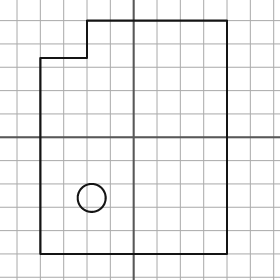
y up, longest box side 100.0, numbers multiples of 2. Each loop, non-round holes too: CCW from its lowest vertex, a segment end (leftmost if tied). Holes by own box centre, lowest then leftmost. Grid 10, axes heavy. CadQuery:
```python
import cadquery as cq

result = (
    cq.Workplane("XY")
    .moveTo(-40.0, -50.0)
    .lineTo(40.0, -50.0)
    .lineTo(40.0, 50.0)
    .lineTo(-20.0, 50.0)
    .lineTo(-20.0, 34.0)
    .lineTo(-40.0, 34.0)
    .close()
    .moveTo(-18.0, -26.0)
    .circle(6.0)
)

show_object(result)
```